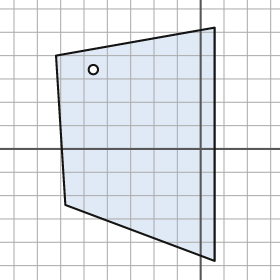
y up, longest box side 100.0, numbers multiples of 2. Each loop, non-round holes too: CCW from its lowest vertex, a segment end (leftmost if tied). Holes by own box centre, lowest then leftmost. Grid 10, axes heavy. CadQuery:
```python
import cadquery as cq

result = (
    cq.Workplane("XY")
    .moveTo(6.0, -48.0)
    .lineTo(6.0, 52.0)
    .lineTo(-62.0, 40.0)
    .lineTo(-58.0, -24.0)
    .close()
    .moveTo(-46.0, 34.0)
    .circle(2.0)
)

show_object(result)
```